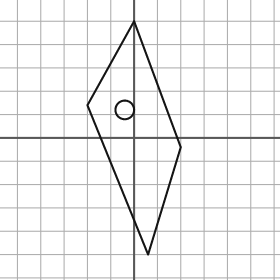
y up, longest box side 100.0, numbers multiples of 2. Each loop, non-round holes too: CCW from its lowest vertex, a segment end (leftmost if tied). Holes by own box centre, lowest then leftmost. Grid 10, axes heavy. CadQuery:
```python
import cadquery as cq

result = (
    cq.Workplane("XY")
    .moveTo(6.0, -50.0)
    .lineTo(20.0, -4.0)
    .lineTo(0.0, 50.0)
    .lineTo(-20.0, 14.0)
    .close()
    .moveTo(-4.0, 12.0)
    .circle(4.0)
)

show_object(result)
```